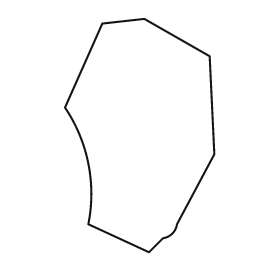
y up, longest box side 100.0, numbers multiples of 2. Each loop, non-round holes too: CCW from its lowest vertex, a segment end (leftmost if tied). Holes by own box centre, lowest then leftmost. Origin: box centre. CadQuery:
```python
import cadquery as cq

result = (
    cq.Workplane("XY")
    .moveTo(4.0, -50.0)
    .lineTo(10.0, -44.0)
    .threePointArc((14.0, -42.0), (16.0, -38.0))
    .lineTo(32.0, -8.0)
    .lineTo(30.0, 34.0)
    .lineTo(2.0, 50.0)
    .lineTo(-16.0, 48.0)
    .lineTo(-32.0, 12.0)
    .threePointArc((-22.0, -12.0), (-22.0, -38.0))
    .close()
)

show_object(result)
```